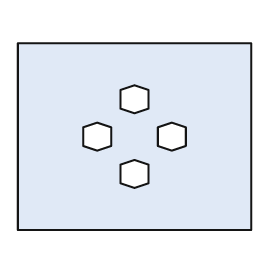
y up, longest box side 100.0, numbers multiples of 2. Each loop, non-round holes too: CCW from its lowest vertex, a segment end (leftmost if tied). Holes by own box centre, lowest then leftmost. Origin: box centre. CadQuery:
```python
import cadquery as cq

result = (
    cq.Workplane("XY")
    .moveTo(-50.0, -40.0)
    .lineTo(50.0, -40.0)
    .lineTo(50.0, 40.0)
    .lineTo(-50.0, 40.0)
    .close()
    .moveTo(0.0, -22.0)
    .lineTo(6.0, -20.0)
    .lineTo(6.0, -12.0)
    .lineTo(0.0, -10.0)
    .lineTo(-6.0, -12.0)
    .lineTo(-6.0, -20.0)
    .close()
    .moveTo(-16.0, -6.0)
    .lineTo(-10.0, -4.0)
    .lineTo(-10.0, 4.0)
    .lineTo(-16.0, 6.0)
    .lineTo(-22.0, 4.0)
    .lineTo(-22.0, -4.0)
    .close()
    .moveTo(16.0, -6.0)
    .lineTo(22.0, -4.0)
    .lineTo(22.0, 4.0)
    .lineTo(16.0, 6.0)
    .lineTo(10.0, 4.0)
    .lineTo(10.0, -4.0)
    .close()
    .moveTo(0.0, 10.0)
    .lineTo(6.0, 12.0)
    .lineTo(6.0, 20.0)
    .lineTo(0.0, 22.0)
    .lineTo(-6.0, 20.0)
    .lineTo(-6.0, 12.0)
    .close()
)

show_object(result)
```